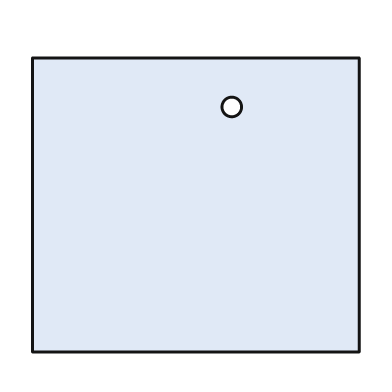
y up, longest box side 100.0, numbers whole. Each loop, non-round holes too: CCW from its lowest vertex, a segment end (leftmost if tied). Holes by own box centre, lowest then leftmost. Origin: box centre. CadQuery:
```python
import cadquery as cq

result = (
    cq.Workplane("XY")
    .moveTo(-50.0, -45.0)
    .lineTo(50.0, -45.0)
    .lineTo(50.0, 45.0)
    .lineTo(-50.0, 45.0)
    .close()
    .moveTo(11.0, 30.0)
    .circle(3.0)
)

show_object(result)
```